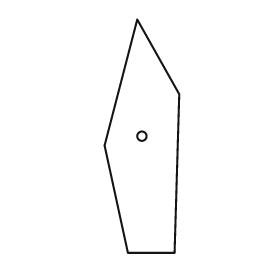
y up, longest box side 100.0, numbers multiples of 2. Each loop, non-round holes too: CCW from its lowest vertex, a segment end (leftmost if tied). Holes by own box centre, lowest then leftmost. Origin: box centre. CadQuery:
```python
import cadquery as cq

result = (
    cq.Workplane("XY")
    .moveTo(-6.0, -50.0)
    .lineTo(14.0, -50.0)
    .lineTo(16.0, 18.0)
    .lineTo(-2.0, 50.0)
    .lineTo(-16.0, -4.0)
    .close()
    .moveTo(0.0, 0.0)
    .circle(2.0)
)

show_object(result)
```